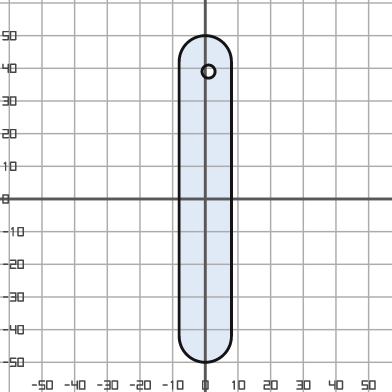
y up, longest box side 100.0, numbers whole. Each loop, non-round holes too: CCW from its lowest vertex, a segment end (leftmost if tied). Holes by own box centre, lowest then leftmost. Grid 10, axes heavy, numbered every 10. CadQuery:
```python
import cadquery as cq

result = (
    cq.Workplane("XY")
    .moveTo(-8.0, -42.0)
    .threePointArc((0.0, -50.0), (8.0, -42.0))
    .lineTo(8.0, 42.0)
    .threePointArc((0.0, 50.0), (-8.0, 42.0))
    .close()
    .moveTo(1.0, 39.0)
    .circle(2.0)
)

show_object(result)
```